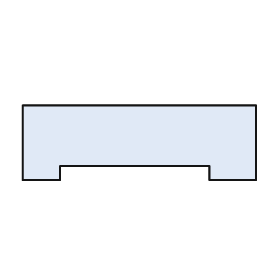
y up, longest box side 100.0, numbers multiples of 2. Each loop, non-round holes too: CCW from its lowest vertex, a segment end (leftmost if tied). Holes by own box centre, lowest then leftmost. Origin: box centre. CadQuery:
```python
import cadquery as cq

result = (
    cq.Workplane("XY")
    .moveTo(-50.0, -16.0)
    .lineTo(-34.0, -16.0)
    .lineTo(-34.0, -10.0)
    .lineTo(30.0, -10.0)
    .lineTo(30.0, -16.0)
    .lineTo(50.0, -16.0)
    .lineTo(50.0, 16.0)
    .lineTo(-50.0, 16.0)
    .close()
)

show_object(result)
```